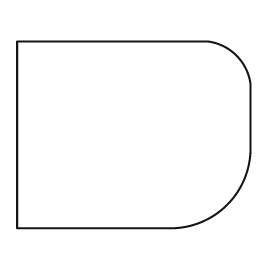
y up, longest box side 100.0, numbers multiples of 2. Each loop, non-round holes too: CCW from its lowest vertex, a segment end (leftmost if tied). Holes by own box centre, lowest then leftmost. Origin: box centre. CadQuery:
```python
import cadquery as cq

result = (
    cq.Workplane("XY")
    .moveTo(-50.0, -40.0)
    .lineTo(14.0, -40.0)
    .threePointArc((40.0, -30.0), (50.0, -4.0))
    .lineTo(50.0, 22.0)
    .threePointArc((44.0, 34.0), (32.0, 40.0))
    .lineTo(-50.0, 40.0)
    .close()
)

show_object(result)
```